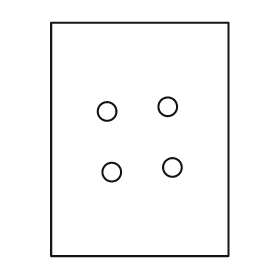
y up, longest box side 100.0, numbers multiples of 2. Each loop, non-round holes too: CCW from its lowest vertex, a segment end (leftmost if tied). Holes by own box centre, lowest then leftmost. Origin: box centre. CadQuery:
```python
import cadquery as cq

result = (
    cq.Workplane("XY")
    .moveTo(-38.0, -50.0)
    .lineTo(38.0, -50.0)
    .lineTo(38.0, 50.0)
    .lineTo(-38.0, 50.0)
    .close()
    .moveTo(-12.0, -14.0)
    .circle(4.0)
    .moveTo(14.0, -12.0)
    .circle(4.0)
    .moveTo(-14.0, 12.0)
    .circle(4.0)
    .moveTo(12.0, 14.0)
    .circle(4.0)
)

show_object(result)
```